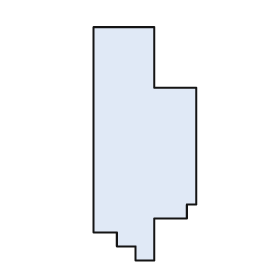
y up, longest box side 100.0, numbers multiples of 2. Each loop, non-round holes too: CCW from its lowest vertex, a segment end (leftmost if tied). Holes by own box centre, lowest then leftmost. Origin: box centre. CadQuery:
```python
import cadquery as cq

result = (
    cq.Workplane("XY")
    .moveTo(-4.0, -50.0)
    .lineTo(4.0, -50.0)
    .lineTo(4.0, -32.0)
    .lineTo(18.0, -32.0)
    .lineTo(18.0, -26.0)
    .lineTo(22.0, -26.0)
    .lineTo(22.0, 24.0)
    .lineTo(4.0, 24.0)
    .lineTo(4.0, 50.0)
    .lineTo(-22.0, 50.0)
    .lineTo(-22.0, -38.0)
    .lineTo(-12.0, -38.0)
    .lineTo(-12.0, -44.0)
    .lineTo(-4.0, -44.0)
    .close()
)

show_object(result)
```